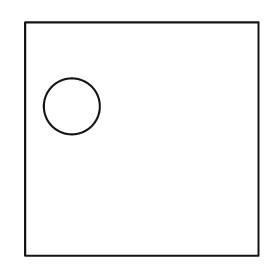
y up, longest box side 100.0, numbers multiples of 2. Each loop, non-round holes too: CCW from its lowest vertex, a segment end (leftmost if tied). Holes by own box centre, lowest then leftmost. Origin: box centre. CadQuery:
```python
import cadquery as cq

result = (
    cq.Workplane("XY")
    .moveTo(-50.0, -50.0)
    .lineTo(50.0, -50.0)
    .lineTo(50.0, 50.0)
    .lineTo(-50.0, 50.0)
    .close()
    .moveTo(-30.0, 14.0)
    .circle(12.0)
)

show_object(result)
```